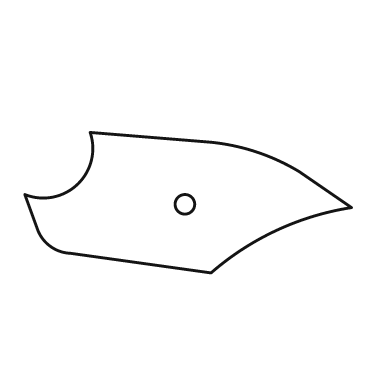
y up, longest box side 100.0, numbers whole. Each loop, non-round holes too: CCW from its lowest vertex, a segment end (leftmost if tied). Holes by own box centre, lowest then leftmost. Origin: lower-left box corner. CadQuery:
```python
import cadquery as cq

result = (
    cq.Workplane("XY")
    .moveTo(57.0, 0.0)
    .threePointArc((77.0, 13.0), (100.0, 20.0))
    .lineTo(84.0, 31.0)
    .threePointArc((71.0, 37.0), (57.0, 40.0))
    .lineTo(20.0, 43.0)
    .threePointArc((16.0, 27.0), (0.0, 24.0))
    .lineTo(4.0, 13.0)
    .threePointArc((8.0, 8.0), (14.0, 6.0))
    .close()
    .moveTo(49.0, 21.0)
    .circle(3.0)
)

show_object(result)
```